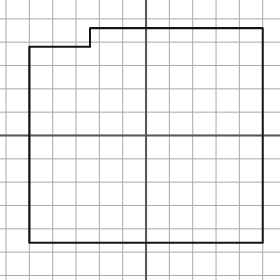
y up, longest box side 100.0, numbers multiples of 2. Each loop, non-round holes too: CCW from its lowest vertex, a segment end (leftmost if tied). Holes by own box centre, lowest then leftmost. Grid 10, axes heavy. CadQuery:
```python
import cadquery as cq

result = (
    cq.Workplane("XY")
    .moveTo(-50.0, -46.0)
    .lineTo(50.0, -46.0)
    .lineTo(50.0, 46.0)
    .lineTo(-24.0, 46.0)
    .lineTo(-24.0, 38.0)
    .lineTo(-50.0, 38.0)
    .close()
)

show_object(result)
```